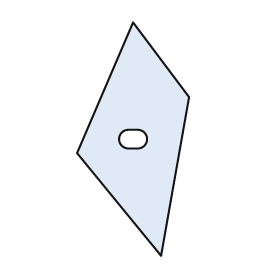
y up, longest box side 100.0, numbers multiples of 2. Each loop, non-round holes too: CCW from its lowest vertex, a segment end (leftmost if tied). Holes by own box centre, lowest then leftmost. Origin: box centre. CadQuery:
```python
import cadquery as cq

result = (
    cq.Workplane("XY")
    .moveTo(12.0, -50.0)
    .lineTo(24.0, 18.0)
    .lineTo(0.0, 50.0)
    .lineTo(-24.0, -6.0)
    .close()
    .moveTo(-2.0, -4.0)
    .lineTo(2.0, -4.0)
    .threePointArc((6.0, 0.0), (2.0, 4.0))
    .lineTo(-2.0, 4.0)
    .threePointArc((-6.0, 0.0), (-2.0, -4.0))
    .close()
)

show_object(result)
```